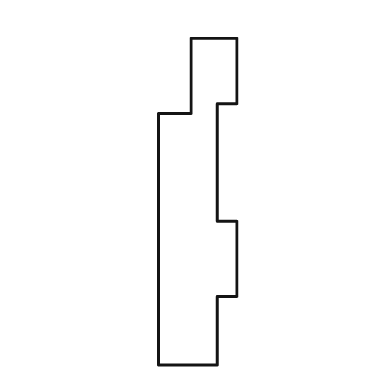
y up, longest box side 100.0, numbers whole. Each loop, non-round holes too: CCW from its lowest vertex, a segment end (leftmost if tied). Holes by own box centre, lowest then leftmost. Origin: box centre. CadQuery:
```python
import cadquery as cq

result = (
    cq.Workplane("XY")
    .moveTo(-12.0, -50.0)
    .lineTo(6.0, -50.0)
    .lineTo(6.0, -29.0)
    .lineTo(12.0, -29.0)
    .lineTo(12.0, -6.0)
    .lineTo(6.0, -6.0)
    .lineTo(6.0, 30.0)
    .lineTo(12.0, 30.0)
    .lineTo(12.0, 50.0)
    .lineTo(-2.0, 50.0)
    .lineTo(-2.0, 27.0)
    .lineTo(-12.0, 27.0)
    .close()
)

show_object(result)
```